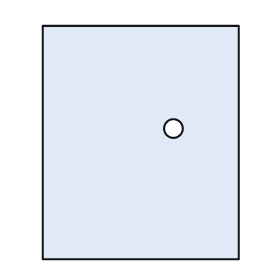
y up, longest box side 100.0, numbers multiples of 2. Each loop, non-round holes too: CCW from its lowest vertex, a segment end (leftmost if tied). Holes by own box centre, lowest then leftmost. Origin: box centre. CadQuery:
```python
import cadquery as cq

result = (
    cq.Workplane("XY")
    .moveTo(-42.0, -50.0)
    .lineTo(42.0, -50.0)
    .lineTo(42.0, 50.0)
    .lineTo(-42.0, 50.0)
    .close()
    .moveTo(14.0, 6.0)
    .circle(4.0)
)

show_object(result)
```